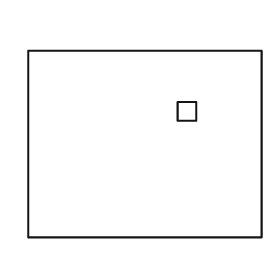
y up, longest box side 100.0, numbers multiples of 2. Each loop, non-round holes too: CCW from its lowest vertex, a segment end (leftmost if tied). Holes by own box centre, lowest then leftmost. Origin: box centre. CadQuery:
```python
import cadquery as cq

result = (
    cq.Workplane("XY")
    .moveTo(-50.0, -40.0)
    .lineTo(50.0, -40.0)
    .lineTo(50.0, 40.0)
    .lineTo(-50.0, 40.0)
    .close()
    .moveTo(14.0, 10.0)
    .lineTo(22.0, 10.0)
    .lineTo(22.0, 18.0)
    .lineTo(14.0, 18.0)
    .close()
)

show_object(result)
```